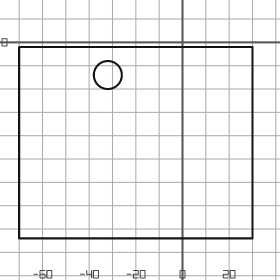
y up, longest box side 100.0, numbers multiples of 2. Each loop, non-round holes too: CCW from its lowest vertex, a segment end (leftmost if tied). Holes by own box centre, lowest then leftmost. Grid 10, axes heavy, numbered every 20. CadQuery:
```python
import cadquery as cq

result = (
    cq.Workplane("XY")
    .moveTo(-70.0, -84.0)
    .lineTo(30.0, -84.0)
    .lineTo(30.0, -2.0)
    .lineTo(-70.0, -2.0)
    .close()
    .moveTo(-32.0, -14.0)
    .circle(6.0)
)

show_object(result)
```